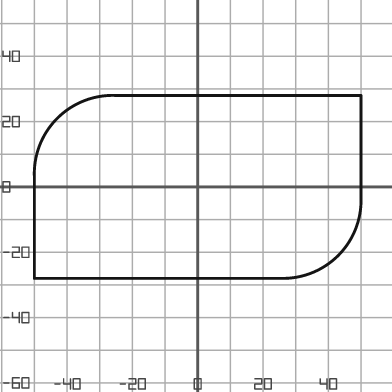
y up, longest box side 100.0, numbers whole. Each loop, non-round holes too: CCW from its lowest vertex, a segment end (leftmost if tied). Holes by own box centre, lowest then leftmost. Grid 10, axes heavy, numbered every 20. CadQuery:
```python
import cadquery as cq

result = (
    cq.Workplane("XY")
    .moveTo(-50.0, -28.0)
    .lineTo(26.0, -28.0)
    .threePointArc((43.0, -21.0), (50.0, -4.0))
    .lineTo(50.0, 28.0)
    .lineTo(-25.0, 28.0)
    .threePointArc((-43.0, 21.0), (-50.0, 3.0))
    .close()
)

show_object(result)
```